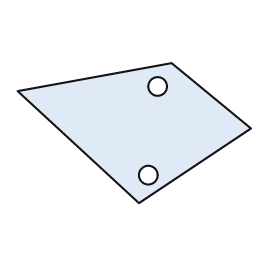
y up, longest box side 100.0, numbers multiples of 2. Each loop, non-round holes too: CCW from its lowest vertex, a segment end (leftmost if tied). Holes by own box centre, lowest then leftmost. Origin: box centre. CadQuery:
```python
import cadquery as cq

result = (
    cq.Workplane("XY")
    .moveTo(2.0, -30.0)
    .lineTo(50.0, 2.0)
    .lineTo(16.0, 30.0)
    .lineTo(-50.0, 18.0)
    .close()
    .moveTo(6.0, -18.0)
    .circle(4.0)
    .moveTo(10.0, 20.0)
    .circle(4.0)
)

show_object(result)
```